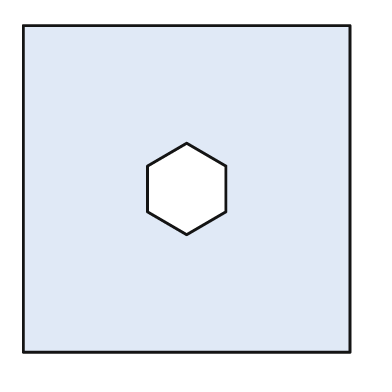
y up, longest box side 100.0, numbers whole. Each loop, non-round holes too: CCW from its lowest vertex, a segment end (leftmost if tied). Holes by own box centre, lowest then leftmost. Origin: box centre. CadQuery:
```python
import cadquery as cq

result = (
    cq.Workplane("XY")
    .moveTo(-50.0, -50.0)
    .lineTo(50.0, -50.0)
    .lineTo(50.0, 50.0)
    .lineTo(-50.0, 50.0)
    .close()
    .moveTo(0.0, -14.0)
    .lineTo(12.0, -7.0)
    .lineTo(12.0, 7.0)
    .lineTo(0.0, 14.0)
    .lineTo(-12.0, 7.0)
    .lineTo(-12.0, -7.0)
    .close()
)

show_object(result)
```